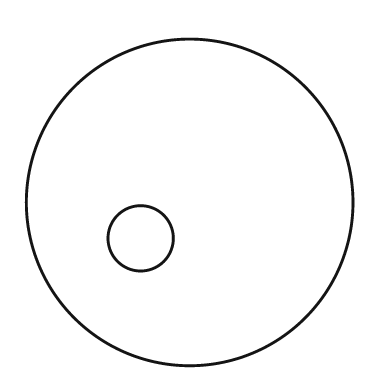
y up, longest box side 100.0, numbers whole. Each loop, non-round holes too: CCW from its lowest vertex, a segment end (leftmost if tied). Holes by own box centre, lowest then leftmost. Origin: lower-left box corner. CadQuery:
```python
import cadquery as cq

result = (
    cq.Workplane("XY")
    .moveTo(50.0, 50.0)
    .circle(50.0)
    .moveTo(35.0, 39.0)
    .circle(10.0)
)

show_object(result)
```